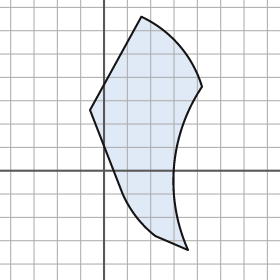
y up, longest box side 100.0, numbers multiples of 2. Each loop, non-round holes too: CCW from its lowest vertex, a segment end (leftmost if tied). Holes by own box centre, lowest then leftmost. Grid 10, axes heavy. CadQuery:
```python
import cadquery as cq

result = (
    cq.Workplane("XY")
    .moveTo(36.0, -34.0)
    .threePointArc((30.0, 2.0), (42.0, 36.0))
    .threePointArc((32.0, 54.0), (16.0, 66.0))
    .lineTo(-6.0, 26.0)
    .lineTo(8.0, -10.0)
    .threePointArc((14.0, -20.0), (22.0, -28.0))
    .close()
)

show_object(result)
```